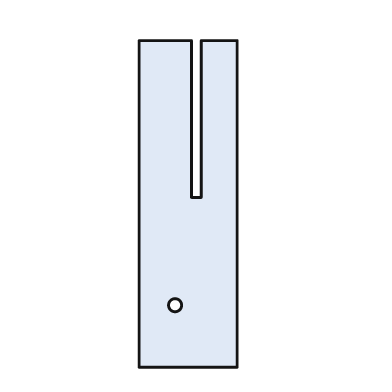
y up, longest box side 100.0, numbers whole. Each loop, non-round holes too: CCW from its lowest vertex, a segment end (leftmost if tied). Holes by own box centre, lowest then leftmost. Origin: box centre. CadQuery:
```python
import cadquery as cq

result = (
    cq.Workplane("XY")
    .moveTo(-15.0, -50.0)
    .lineTo(15.0, -50.0)
    .lineTo(15.0, 50.0)
    .lineTo(4.0, 50.0)
    .lineTo(4.0, 2.0)
    .lineTo(1.0, 2.0)
    .lineTo(1.0, 50.0)
    .lineTo(-15.0, 50.0)
    .close()
    .moveTo(-4.0, -31.0)
    .circle(2.0)
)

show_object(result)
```